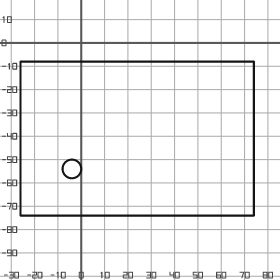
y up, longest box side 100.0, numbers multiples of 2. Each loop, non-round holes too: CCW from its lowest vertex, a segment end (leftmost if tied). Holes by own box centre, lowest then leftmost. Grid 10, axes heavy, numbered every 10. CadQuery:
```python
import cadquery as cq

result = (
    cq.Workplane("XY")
    .moveTo(-26.0, -74.0)
    .lineTo(74.0, -74.0)
    .lineTo(74.0, -8.0)
    .lineTo(-26.0, -8.0)
    .close()
    .moveTo(-4.0, -54.0)
    .circle(4.0)
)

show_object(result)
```